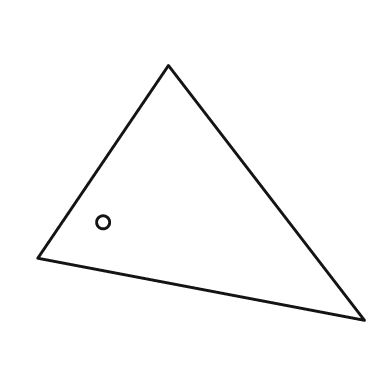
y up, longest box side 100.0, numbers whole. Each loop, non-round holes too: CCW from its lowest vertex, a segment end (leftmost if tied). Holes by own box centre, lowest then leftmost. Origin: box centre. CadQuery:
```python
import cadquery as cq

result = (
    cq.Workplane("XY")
    .moveTo(50.0, -39.0)
    .lineTo(-10.0, 39.0)
    .lineTo(-50.0, -20.0)
    .close()
    .moveTo(-30.0, -9.0)
    .circle(2.0)
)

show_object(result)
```